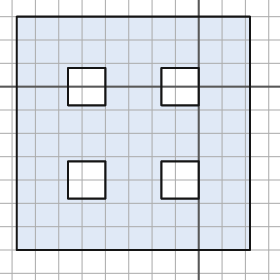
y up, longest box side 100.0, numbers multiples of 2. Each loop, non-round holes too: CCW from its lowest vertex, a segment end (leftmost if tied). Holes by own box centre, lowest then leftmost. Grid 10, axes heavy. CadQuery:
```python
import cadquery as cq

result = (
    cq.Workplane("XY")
    .moveTo(-78.0, -70.0)
    .lineTo(22.0, -70.0)
    .lineTo(22.0, 30.0)
    .lineTo(-78.0, 30.0)
    .close()
    .moveTo(-56.0, -48.0)
    .lineTo(-40.0, -48.0)
    .lineTo(-40.0, -32.0)
    .lineTo(-56.0, -32.0)
    .close()
    .moveTo(-16.0, -48.0)
    .lineTo(0.0, -48.0)
    .lineTo(0.0, -32.0)
    .lineTo(-16.0, -32.0)
    .close()
    .moveTo(-56.0, -8.0)
    .lineTo(-40.0, -8.0)
    .lineTo(-40.0, 8.0)
    .lineTo(-56.0, 8.0)
    .close()
    .moveTo(-16.0, -8.0)
    .lineTo(0.0, -8.0)
    .lineTo(0.0, 8.0)
    .lineTo(-16.0, 8.0)
    .close()
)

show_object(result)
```